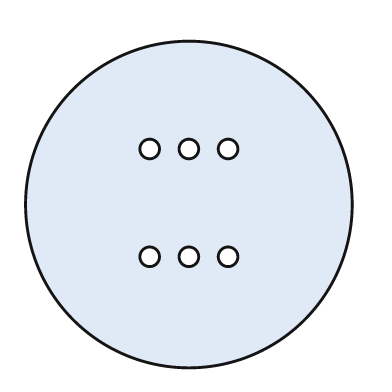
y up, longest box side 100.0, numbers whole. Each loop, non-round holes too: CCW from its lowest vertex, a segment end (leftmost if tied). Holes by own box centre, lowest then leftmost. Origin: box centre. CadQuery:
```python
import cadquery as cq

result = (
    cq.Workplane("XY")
    .moveTo(0.0, 0.0)
    .circle(50.0)
    .moveTo(-12.0, -16.0)
    .circle(3.0)
    .moveTo(0.0, -16.0)
    .circle(3.0)
    .moveTo(12.0, -16.0)
    .circle(3.0)
    .moveTo(-12.0, 17.0)
    .circle(3.0)
    .moveTo(0.0, 17.0)
    .circle(3.0)
    .moveTo(12.0, 17.0)
    .circle(3.0)
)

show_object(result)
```